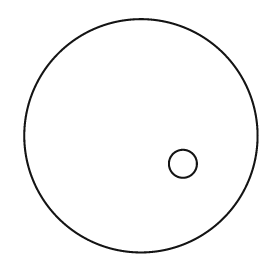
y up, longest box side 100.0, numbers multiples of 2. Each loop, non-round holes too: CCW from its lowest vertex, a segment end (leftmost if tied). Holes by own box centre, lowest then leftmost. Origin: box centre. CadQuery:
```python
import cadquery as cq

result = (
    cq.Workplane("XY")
    .moveTo(0.0, 0.0)
    .circle(50.0)
    .moveTo(18.0, -12.0)
    .circle(6.0)
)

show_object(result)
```